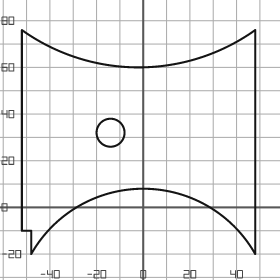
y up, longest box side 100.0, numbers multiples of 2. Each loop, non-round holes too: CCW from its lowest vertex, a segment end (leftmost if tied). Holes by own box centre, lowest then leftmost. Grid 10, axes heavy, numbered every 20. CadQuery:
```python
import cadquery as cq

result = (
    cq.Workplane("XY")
    .moveTo(-48.0, -20.0)
    .threePointArc((0.0, 8.0), (48.0, -20.0))
    .lineTo(48.0, 76.0)
    .threePointArc((-2.0, 60.0), (-52.0, 76.0))
    .lineTo(-52.0, -10.0)
    .lineTo(-48.0, -10.0)
    .close()
    .moveTo(-14.0, 32.0)
    .circle(6.0)
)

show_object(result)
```